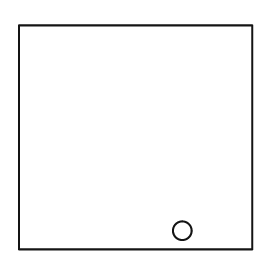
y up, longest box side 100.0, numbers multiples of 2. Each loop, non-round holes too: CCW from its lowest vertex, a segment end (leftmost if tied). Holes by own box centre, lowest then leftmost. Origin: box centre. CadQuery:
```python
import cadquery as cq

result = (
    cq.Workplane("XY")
    .moveTo(-50.0, -48.0)
    .lineTo(50.0, -48.0)
    .lineTo(50.0, 48.0)
    .lineTo(-50.0, 48.0)
    .close()
    .moveTo(20.0, -40.0)
    .circle(4.0)
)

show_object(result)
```